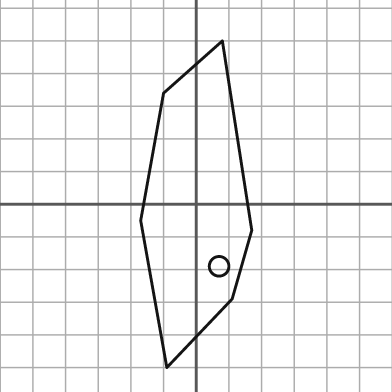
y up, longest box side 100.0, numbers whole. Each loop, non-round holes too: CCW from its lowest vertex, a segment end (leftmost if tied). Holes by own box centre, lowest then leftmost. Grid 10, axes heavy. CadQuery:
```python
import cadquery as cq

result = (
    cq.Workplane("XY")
    .moveTo(-9.0, -50.0)
    .lineTo(11.0, -29.0)
    .lineTo(17.0, -8.0)
    .lineTo(8.0, 50.0)
    .lineTo(-10.0, 34.0)
    .lineTo(-17.0, -5.0)
    .close()
    .moveTo(7.0, -19.0)
    .circle(3.0)
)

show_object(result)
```